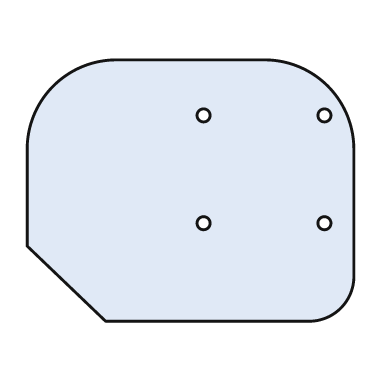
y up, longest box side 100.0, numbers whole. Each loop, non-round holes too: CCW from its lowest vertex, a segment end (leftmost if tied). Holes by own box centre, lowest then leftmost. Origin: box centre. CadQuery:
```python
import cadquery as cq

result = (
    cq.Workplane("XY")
    .moveTo(-26.0, -40.0)
    .lineTo(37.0, -40.0)
    .threePointArc((46.0, -36.0), (50.0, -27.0))
    .lineTo(50.0, 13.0)
    .threePointArc((42.0, 32.0), (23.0, 40.0))
    .lineTo(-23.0, 40.0)
    .threePointArc((-42.0, 32.0), (-50.0, 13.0))
    .lineTo(-50.0, -17.0)
    .close()
    .moveTo(4.0, -10.0)
    .circle(2.0)
    .moveTo(41.0, -10.0)
    .circle(2.0)
    .moveTo(4.0, 23.0)
    .circle(2.0)
    .moveTo(41.0, 23.0)
    .circle(2.0)
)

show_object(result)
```